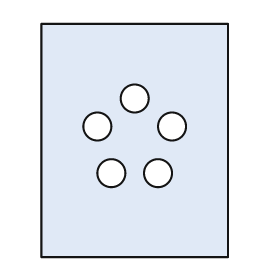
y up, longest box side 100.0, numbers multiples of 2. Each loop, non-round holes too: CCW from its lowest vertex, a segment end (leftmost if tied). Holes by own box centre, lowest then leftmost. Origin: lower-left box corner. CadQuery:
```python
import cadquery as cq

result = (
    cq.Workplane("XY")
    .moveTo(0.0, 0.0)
    .lineTo(80.0, 0.0)
    .lineTo(80.0, 100.0)
    .lineTo(0.0, 100.0)
    .close()
    .moveTo(30.0, 36.0)
    .circle(6.0)
    .moveTo(50.0, 36.0)
    .circle(6.0)
    .moveTo(24.0, 56.0)
    .circle(6.0)
    .moveTo(56.0, 56.0)
    .circle(6.0)
    .moveTo(40.0, 68.0)
    .circle(6.0)
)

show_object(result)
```